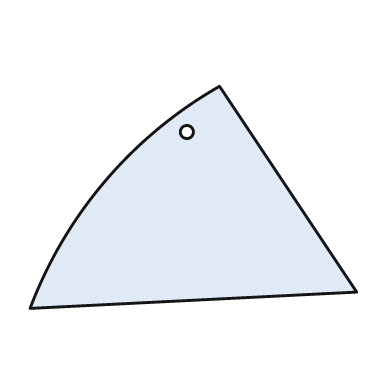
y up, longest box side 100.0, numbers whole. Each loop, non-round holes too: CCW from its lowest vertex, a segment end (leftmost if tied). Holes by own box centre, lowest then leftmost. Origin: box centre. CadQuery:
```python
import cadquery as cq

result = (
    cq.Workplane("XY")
    .moveTo(-50.0, -34.0)
    .lineTo(50.0, -29.0)
    .lineTo(8.0, 34.0)
    .threePointArc((-27.0, 5.0), (-50.0, -34.0))
    .close()
    .moveTo(-2.0, 20.0)
    .circle(2.0)
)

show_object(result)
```